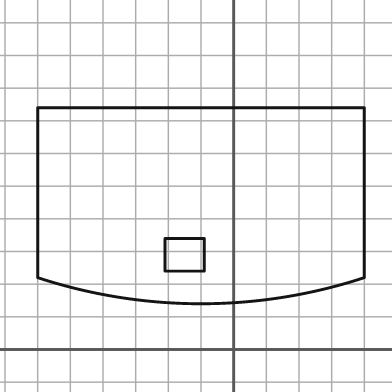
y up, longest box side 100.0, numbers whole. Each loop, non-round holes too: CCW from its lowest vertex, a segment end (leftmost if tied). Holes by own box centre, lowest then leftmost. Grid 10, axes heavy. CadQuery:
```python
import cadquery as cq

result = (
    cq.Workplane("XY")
    .moveTo(-60.0, 22.0)
    .threePointArc((-10.0, 14.0), (40.0, 22.0))
    .lineTo(40.0, 74.0)
    .lineTo(-60.0, 74.0)
    .close()
    .moveTo(-21.0, 24.0)
    .lineTo(-9.0, 24.0)
    .lineTo(-9.0, 34.0)
    .lineTo(-21.0, 34.0)
    .close()
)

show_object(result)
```